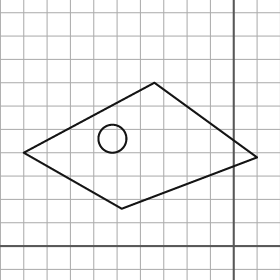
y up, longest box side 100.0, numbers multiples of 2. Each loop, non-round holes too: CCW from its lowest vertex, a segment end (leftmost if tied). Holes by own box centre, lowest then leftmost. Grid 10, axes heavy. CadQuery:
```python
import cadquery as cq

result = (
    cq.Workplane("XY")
    .moveTo(-48.0, 16.0)
    .lineTo(10.0, 38.0)
    .lineTo(-34.0, 70.0)
    .lineTo(-90.0, 40.0)
    .close()
    .moveTo(-52.0, 46.0)
    .circle(6.0)
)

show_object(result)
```